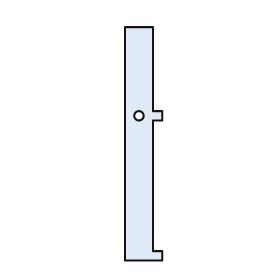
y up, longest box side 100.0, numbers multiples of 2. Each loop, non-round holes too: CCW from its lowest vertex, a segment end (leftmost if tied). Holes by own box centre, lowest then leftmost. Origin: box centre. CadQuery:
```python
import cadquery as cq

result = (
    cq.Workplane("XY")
    .moveTo(-8.0, -50.0)
    .lineTo(8.0, -50.0)
    .lineTo(8.0, -46.0)
    .lineTo(4.0, -46.0)
    .lineTo(4.0, 10.0)
    .lineTo(8.0, 10.0)
    .lineTo(8.0, 14.0)
    .lineTo(4.0, 14.0)
    .lineTo(4.0, 50.0)
    .lineTo(-8.0, 50.0)
    .close()
    .moveTo(-2.0, 12.0)
    .circle(2.0)
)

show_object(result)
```